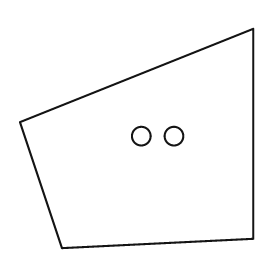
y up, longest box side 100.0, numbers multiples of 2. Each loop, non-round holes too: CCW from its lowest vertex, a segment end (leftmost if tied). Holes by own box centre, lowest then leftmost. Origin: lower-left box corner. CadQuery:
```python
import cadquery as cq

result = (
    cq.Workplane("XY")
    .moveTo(18.0, 0.0)
    .lineTo(100.0, 4.0)
    .lineTo(100.0, 94.0)
    .lineTo(0.0, 54.0)
    .close()
    .moveTo(52.0, 48.0)
    .circle(4.0)
    .moveTo(66.0, 48.0)
    .circle(4.0)
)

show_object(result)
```